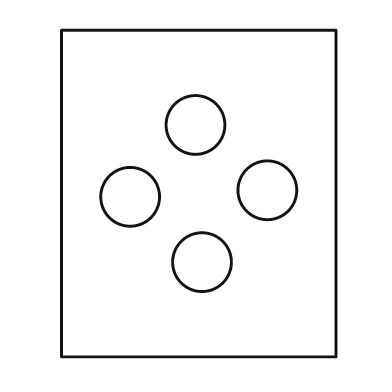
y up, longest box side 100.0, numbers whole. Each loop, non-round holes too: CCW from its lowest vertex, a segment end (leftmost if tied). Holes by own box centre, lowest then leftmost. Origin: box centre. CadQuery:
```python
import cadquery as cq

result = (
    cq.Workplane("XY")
    .moveTo(-42.0, -50.0)
    .lineTo(42.0, -50.0)
    .lineTo(42.0, 50.0)
    .lineTo(-42.0, 50.0)
    .close()
    .moveTo(1.0, -21.0)
    .circle(9.0)
    .moveTo(-21.0, -1.0)
    .circle(9.0)
    .moveTo(21.0, 1.0)
    .circle(9.0)
    .moveTo(-1.0, 21.0)
    .circle(9.0)
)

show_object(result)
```